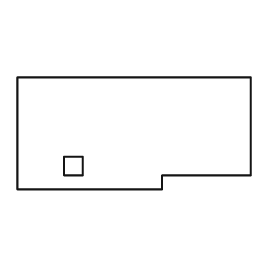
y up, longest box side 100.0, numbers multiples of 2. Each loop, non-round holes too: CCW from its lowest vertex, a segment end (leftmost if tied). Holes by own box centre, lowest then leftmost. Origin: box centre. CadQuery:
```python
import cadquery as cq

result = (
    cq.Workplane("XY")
    .moveTo(-50.0, -24.0)
    .lineTo(12.0, -24.0)
    .lineTo(12.0, -18.0)
    .lineTo(50.0, -18.0)
    .lineTo(50.0, 24.0)
    .lineTo(-50.0, 24.0)
    .close()
    .moveTo(-30.0, -18.0)
    .lineTo(-22.0, -18.0)
    .lineTo(-22.0, -10.0)
    .lineTo(-30.0, -10.0)
    .close()
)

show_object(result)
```